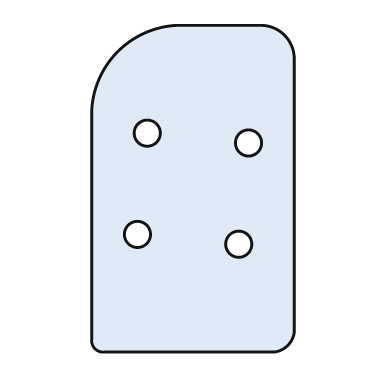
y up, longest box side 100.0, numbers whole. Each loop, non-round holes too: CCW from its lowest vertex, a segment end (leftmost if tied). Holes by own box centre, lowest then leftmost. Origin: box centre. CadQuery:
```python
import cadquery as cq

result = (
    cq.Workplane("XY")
    .moveTo(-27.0, -50.0)
    .lineTo(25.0, -50.0)
    .threePointArc((29.0, -48.0), (31.0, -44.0))
    .lineTo(31.0, 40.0)
    .threePointArc((28.0, 47.0), (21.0, 50.0))
    .lineTo(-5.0, 50.0)
    .threePointArc((-23.0, 42.0), (-31.0, 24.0))
    .lineTo(-31.0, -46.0)
    .threePointArc((-30.0, -49.0), (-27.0, -50.0))
    .close()
    .moveTo(14.0, -17.0)
    .circle(4.0)
    .moveTo(-17.0, -14.0)
    .circle(4.0)
    .moveTo(17.0, 14.0)
    .circle(4.0)
    .moveTo(-14.0, 17.0)
    .circle(4.0)
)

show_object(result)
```